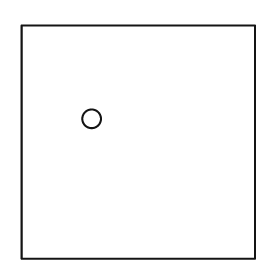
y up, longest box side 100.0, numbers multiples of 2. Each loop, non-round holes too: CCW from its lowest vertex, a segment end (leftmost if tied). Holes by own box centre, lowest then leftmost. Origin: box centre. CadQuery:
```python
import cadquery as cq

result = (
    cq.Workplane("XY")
    .moveTo(-50.0, -50.0)
    .lineTo(50.0, -50.0)
    .lineTo(50.0, 50.0)
    .lineTo(-50.0, 50.0)
    .close()
    .moveTo(-20.0, 10.0)
    .circle(4.0)
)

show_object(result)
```